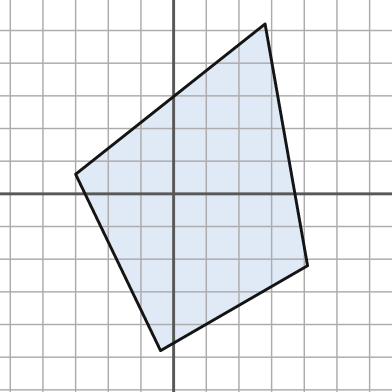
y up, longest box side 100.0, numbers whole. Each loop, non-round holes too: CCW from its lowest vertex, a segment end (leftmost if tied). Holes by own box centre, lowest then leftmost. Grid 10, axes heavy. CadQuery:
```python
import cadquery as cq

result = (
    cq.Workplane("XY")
    .moveTo(-4.0, -48.0)
    .lineTo(41.0, -22.0)
    .lineTo(28.0, 52.0)
    .lineTo(-30.0, 6.0)
    .close()
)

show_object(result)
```